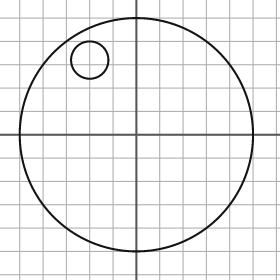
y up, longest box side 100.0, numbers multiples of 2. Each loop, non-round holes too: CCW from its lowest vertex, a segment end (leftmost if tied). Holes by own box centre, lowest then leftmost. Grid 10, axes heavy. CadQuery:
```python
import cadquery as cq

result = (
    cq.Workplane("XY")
    .moveTo(0.0, 0.0)
    .circle(50.0)
    .moveTo(-20.0, 32.0)
    .circle(8.0)
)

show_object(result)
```